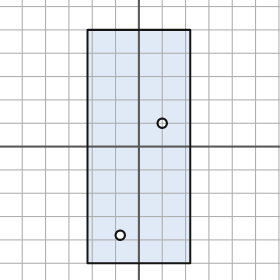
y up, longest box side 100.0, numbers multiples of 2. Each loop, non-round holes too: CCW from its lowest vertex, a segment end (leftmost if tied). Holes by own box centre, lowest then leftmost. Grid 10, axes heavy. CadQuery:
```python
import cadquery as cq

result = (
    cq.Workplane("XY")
    .moveTo(-22.0, -50.0)
    .lineTo(22.0, -50.0)
    .lineTo(22.0, 50.0)
    .lineTo(-22.0, 50.0)
    .close()
    .moveTo(-8.0, -38.0)
    .circle(2.0)
    .moveTo(10.0, 10.0)
    .circle(2.0)
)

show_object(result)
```